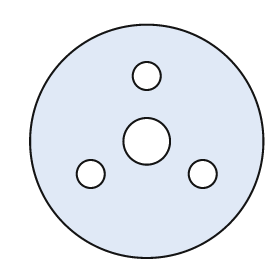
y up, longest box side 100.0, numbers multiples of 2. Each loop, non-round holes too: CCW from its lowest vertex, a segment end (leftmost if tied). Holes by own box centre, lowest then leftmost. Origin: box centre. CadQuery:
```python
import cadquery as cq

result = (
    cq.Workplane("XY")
    .moveTo(0.0, 0.0)
    .circle(50.0)
    .moveTo(-24.0, -14.0)
    .circle(6.0)
    .moveTo(24.0, -14.0)
    .circle(6.0)
    .moveTo(0.0, 0.0)
    .circle(10.0)
    .moveTo(0.0, 28.0)
    .circle(6.0)
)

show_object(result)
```